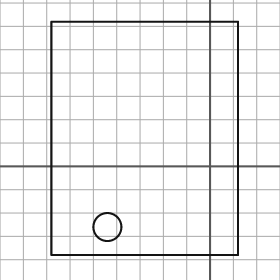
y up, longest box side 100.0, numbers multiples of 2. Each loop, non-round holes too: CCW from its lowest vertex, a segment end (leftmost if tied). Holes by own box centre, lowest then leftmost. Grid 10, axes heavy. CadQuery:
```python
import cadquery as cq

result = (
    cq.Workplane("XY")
    .moveTo(-68.0, -38.0)
    .lineTo(12.0, -38.0)
    .lineTo(12.0, 62.0)
    .lineTo(-68.0, 62.0)
    .close()
    .moveTo(-44.0, -26.0)
    .circle(6.0)
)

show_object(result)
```